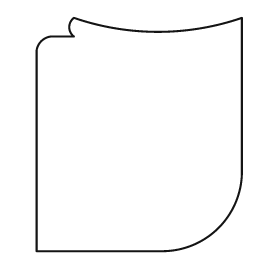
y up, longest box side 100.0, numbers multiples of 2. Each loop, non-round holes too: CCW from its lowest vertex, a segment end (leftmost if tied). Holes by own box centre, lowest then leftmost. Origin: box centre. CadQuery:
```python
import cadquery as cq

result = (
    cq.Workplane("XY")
    .moveTo(-44.0, -50.0)
    .lineTo(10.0, -50.0)
    .threePointArc((34.0, -40.0), (44.0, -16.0))
    .lineTo(44.0, 50.0)
    .threePointArc((8.0, 44.0), (-28.0, 50.0))
    .threePointArc((-30.0, 46.0), (-28.0, 42.0))
    .lineTo(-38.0, 42.0)
    .threePointArc((-42.0, 40.0), (-44.0, 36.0))
    .close()
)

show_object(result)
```